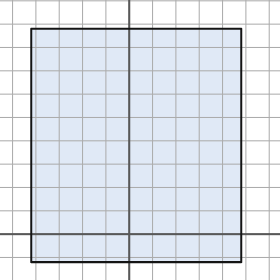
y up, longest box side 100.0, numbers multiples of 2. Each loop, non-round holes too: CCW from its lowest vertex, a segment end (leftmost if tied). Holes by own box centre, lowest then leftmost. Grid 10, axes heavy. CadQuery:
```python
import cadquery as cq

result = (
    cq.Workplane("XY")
    .moveTo(-42.0, -12.0)
    .lineTo(48.0, -12.0)
    .lineTo(48.0, 88.0)
    .lineTo(-42.0, 88.0)
    .close()
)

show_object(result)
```